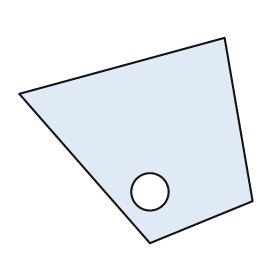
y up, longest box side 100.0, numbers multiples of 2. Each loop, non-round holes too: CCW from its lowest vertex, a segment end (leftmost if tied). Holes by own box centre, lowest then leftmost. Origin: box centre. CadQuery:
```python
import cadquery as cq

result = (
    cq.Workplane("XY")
    .moveTo(6.0, -44.0)
    .lineTo(50.0, -26.0)
    .lineTo(38.0, 44.0)
    .lineTo(-50.0, 20.0)
    .close()
    .moveTo(6.0, -22.0)
    .circle(8.0)
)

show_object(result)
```